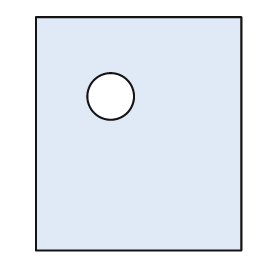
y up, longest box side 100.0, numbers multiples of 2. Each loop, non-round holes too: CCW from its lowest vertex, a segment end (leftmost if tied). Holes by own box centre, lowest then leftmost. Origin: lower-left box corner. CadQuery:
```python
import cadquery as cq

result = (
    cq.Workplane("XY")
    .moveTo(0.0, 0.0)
    .lineTo(88.0, 0.0)
    .lineTo(88.0, 100.0)
    .lineTo(0.0, 100.0)
    .close()
    .moveTo(32.0, 66.0)
    .circle(10.0)
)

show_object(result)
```